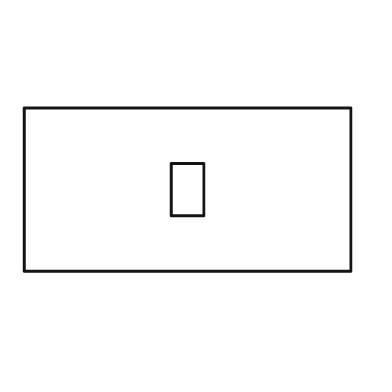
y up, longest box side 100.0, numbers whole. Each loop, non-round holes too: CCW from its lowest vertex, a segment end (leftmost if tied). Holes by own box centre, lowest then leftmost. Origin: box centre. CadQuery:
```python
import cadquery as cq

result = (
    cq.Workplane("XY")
    .moveTo(-50.0, -25.0)
    .lineTo(50.0, -25.0)
    .lineTo(50.0, 25.0)
    .lineTo(-50.0, 25.0)
    .close()
    .moveTo(-5.0, -8.0)
    .lineTo(5.0, -8.0)
    .lineTo(5.0, 8.0)
    .lineTo(-5.0, 8.0)
    .close()
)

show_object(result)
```